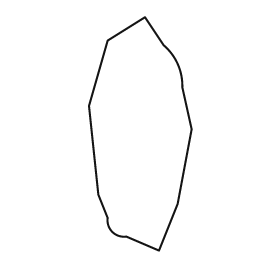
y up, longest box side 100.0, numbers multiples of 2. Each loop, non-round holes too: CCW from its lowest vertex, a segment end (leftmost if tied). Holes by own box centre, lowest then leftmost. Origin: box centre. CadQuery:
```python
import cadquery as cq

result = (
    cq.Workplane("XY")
    .moveTo(8.0, -50.0)
    .lineTo(16.0, -30.0)
    .lineTo(22.0, 2.0)
    .lineTo(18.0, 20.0)
    .threePointArc((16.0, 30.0), (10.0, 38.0))
    .lineTo(2.0, 50.0)
    .lineTo(-14.0, 40.0)
    .lineTo(-22.0, 12.0)
    .lineTo(-18.0, -26.0)
    .lineTo(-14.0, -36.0)
    .threePointArc((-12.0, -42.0), (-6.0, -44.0))
    .close()
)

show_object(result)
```